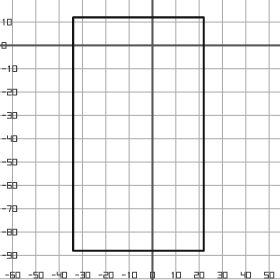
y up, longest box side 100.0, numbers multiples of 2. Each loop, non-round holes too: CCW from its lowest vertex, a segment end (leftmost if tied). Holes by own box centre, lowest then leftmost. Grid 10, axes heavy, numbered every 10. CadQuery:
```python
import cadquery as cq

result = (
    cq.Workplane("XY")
    .moveTo(-34.0, -88.0)
    .lineTo(22.0, -88.0)
    .lineTo(22.0, 12.0)
    .lineTo(-34.0, 12.0)
    .close()
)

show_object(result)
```